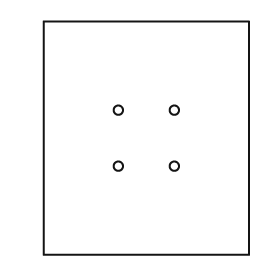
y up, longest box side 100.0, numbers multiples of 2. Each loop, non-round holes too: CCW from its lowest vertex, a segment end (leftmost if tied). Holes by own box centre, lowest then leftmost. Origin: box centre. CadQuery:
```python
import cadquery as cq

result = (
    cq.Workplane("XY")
    .moveTo(-44.0, -50.0)
    .lineTo(44.0, -50.0)
    .lineTo(44.0, 50.0)
    .lineTo(-44.0, 50.0)
    .close()
    .moveTo(-12.0, -12.0)
    .circle(2.0)
    .moveTo(12.0, -12.0)
    .circle(2.0)
    .moveTo(-12.0, 12.0)
    .circle(2.0)
    .moveTo(12.0, 12.0)
    .circle(2.0)
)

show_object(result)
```